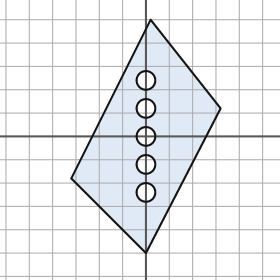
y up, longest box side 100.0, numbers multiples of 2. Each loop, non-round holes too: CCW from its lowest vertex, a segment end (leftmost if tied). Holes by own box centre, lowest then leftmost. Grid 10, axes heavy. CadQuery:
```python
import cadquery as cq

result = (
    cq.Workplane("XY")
    .moveTo(0.0, -50.0)
    .lineTo(32.0, 12.0)
    .lineTo(2.0, 50.0)
    .lineTo(-32.0, -18.0)
    .close()
    .moveTo(0.0, -24.0)
    .circle(4.0)
    .moveTo(0.0, -12.0)
    .circle(4.0)
    .moveTo(0.0, 0.0)
    .circle(4.0)
    .moveTo(0.0, 12.0)
    .circle(4.0)
    .moveTo(0.0, 24.0)
    .circle(4.0)
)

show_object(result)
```